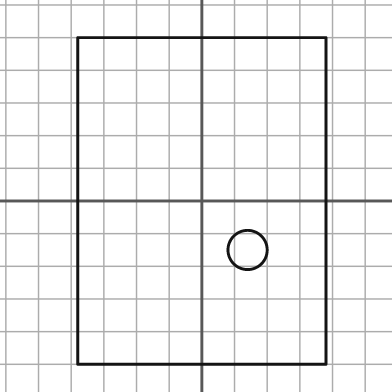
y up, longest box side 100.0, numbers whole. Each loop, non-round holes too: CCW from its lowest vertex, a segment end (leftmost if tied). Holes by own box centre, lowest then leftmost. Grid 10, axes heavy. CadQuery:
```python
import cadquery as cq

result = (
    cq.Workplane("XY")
    .moveTo(-38.0, -50.0)
    .lineTo(38.0, -50.0)
    .lineTo(38.0, 50.0)
    .lineTo(-38.0, 50.0)
    .close()
    .moveTo(14.0, -15.0)
    .circle(6.0)
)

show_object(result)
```